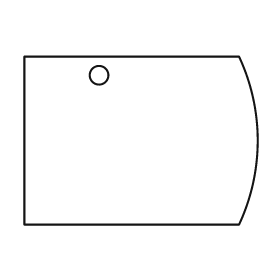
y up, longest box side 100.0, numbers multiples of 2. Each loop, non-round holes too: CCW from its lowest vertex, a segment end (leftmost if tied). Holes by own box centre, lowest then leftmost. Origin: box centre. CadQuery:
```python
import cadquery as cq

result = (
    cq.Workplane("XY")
    .moveTo(-50.0, -36.0)
    .lineTo(42.0, -36.0)
    .threePointArc((50.0, 0.0), (42.0, 36.0))
    .lineTo(-50.0, 36.0)
    .close()
    .moveTo(-18.0, 28.0)
    .circle(4.0)
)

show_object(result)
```